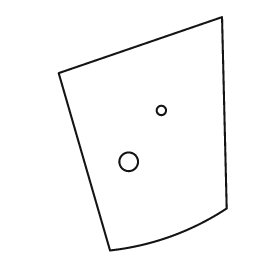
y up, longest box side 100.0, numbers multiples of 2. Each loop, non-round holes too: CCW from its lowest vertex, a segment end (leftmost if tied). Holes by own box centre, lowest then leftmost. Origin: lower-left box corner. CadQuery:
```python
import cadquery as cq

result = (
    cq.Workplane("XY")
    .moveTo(22.0, 0.0)
    .threePointArc((48.0, 6.0), (72.0, 18.0))
    .lineTo(70.0, 100.0)
    .lineTo(0.0, 76.0)
    .close()
    .moveTo(30.0, 38.0)
    .circle(4.0)
    .moveTo(44.0, 60.0)
    .circle(2.0)
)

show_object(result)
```